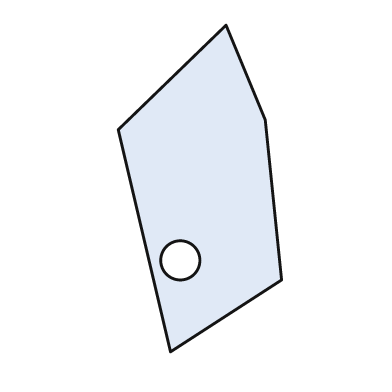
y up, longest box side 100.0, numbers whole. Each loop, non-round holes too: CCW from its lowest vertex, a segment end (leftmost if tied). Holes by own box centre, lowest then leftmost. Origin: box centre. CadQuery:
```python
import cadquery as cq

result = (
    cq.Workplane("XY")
    .moveTo(-9.0, -50.0)
    .lineTo(25.0, -28.0)
    .lineTo(20.0, 21.0)
    .lineTo(8.0, 50.0)
    .lineTo(-25.0, 18.0)
    .close()
    .moveTo(-6.0, -22.0)
    .circle(6.0)
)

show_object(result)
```